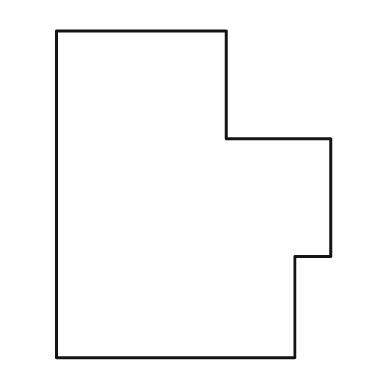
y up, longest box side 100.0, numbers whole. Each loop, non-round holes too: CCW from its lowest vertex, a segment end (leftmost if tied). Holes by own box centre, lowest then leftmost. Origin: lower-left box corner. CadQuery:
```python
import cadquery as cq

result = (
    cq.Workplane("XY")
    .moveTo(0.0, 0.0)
    .lineTo(73.0, 0.0)
    .lineTo(73.0, 31.0)
    .lineTo(84.0, 31.0)
    .lineTo(84.0, 67.0)
    .lineTo(52.0, 67.0)
    .lineTo(52.0, 100.0)
    .lineTo(0.0, 100.0)
    .close()
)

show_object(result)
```